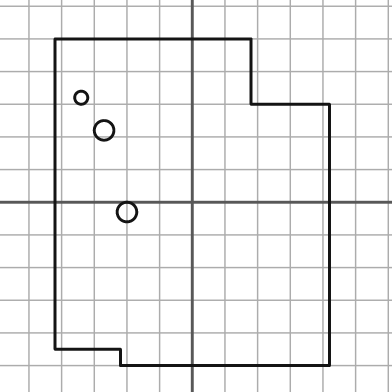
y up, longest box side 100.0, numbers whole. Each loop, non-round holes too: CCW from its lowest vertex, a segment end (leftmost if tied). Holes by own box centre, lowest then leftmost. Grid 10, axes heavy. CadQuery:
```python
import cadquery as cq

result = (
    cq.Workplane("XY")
    .moveTo(-22.0, -50.0)
    .lineTo(42.0, -50.0)
    .lineTo(42.0, 30.0)
    .lineTo(18.0, 30.0)
    .lineTo(18.0, 50.0)
    .lineTo(-42.0, 50.0)
    .lineTo(-42.0, -45.0)
    .lineTo(-22.0, -45.0)
    .close()
    .moveTo(-20.0, -3.0)
    .circle(3.0)
    .moveTo(-27.0, 22.0)
    .circle(3.0)
    .moveTo(-34.0, 32.0)
    .circle(2.0)
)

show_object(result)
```